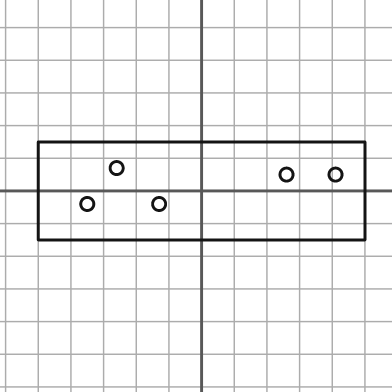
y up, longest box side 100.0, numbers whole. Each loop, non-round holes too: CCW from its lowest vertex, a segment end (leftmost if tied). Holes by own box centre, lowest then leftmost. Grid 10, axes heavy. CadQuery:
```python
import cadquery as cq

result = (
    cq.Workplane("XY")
    .moveTo(-50.0, -15.0)
    .lineTo(50.0, -15.0)
    .lineTo(50.0, 15.0)
    .lineTo(-50.0, 15.0)
    .close()
    .moveTo(-35.0, -4.0)
    .circle(2.0)
    .moveTo(-13.0, -4.0)
    .circle(2.0)
    .moveTo(26.0, 5.0)
    .circle(2.0)
    .moveTo(41.0, 5.0)
    .circle(2.0)
    .moveTo(-26.0, 7.0)
    .circle(2.0)
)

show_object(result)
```